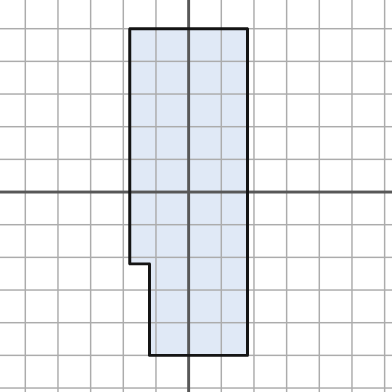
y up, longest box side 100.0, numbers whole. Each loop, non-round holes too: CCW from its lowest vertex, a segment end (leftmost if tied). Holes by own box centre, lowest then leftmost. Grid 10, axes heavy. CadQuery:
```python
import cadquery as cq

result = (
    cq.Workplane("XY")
    .moveTo(-12.0, -50.0)
    .lineTo(18.0, -50.0)
    .lineTo(18.0, 50.0)
    .lineTo(-18.0, 50.0)
    .lineTo(-18.0, -22.0)
    .lineTo(-12.0, -22.0)
    .close()
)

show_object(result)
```